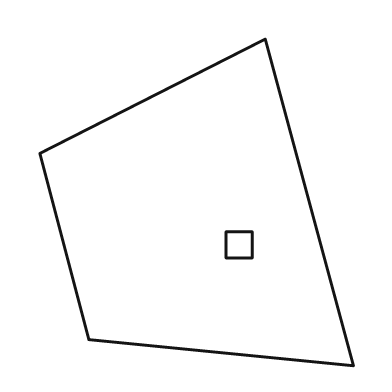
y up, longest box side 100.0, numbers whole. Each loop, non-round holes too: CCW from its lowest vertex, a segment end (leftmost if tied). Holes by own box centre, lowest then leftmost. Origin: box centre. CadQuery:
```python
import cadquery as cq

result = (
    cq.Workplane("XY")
    .moveTo(48.0, -50.0)
    .lineTo(21.0, 50.0)
    .lineTo(-48.0, 15.0)
    .lineTo(-33.0, -42.0)
    .close()
    .moveTo(9.0, -17.0)
    .lineTo(17.0, -17.0)
    .lineTo(17.0, -9.0)
    .lineTo(9.0, -9.0)
    .close()
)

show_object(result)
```